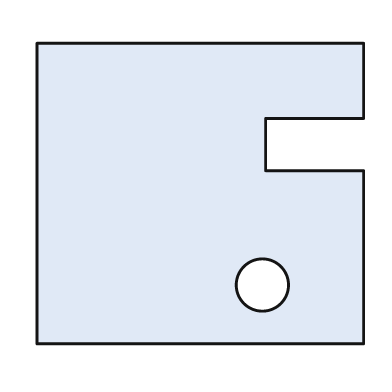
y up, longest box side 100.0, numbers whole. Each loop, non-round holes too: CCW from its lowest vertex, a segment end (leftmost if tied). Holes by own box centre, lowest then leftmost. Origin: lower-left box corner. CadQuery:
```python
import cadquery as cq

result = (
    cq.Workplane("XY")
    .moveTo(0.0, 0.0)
    .lineTo(100.0, 0.0)
    .lineTo(100.0, 53.0)
    .lineTo(70.0, 53.0)
    .lineTo(70.0, 69.0)
    .lineTo(100.0, 69.0)
    .lineTo(100.0, 92.0)
    .lineTo(0.0, 92.0)
    .close()
    .moveTo(69.0, 18.0)
    .circle(8.0)
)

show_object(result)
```